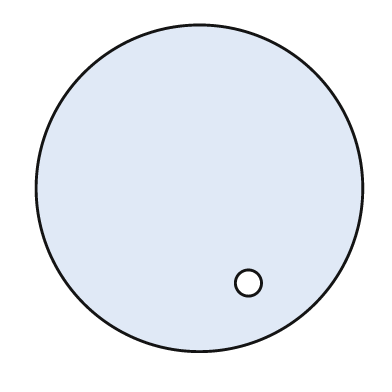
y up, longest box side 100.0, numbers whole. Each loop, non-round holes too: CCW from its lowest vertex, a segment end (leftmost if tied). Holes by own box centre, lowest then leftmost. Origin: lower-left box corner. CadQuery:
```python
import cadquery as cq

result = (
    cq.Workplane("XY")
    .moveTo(50.0, 50.0)
    .circle(50.0)
    .moveTo(65.0, 21.0)
    .circle(4.0)
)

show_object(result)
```